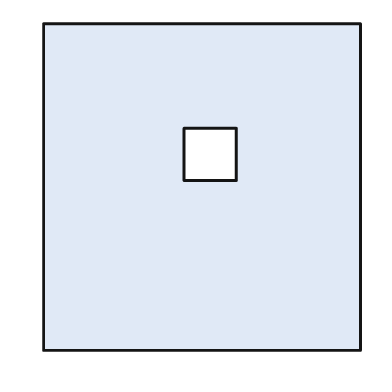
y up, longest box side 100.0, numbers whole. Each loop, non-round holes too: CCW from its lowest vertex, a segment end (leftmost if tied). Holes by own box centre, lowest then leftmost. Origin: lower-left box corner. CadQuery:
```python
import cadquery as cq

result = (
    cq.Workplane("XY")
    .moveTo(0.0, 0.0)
    .lineTo(97.0, 0.0)
    .lineTo(97.0, 100.0)
    .lineTo(0.0, 100.0)
    .close()
    .moveTo(43.0, 52.0)
    .lineTo(59.0, 52.0)
    .lineTo(59.0, 68.0)
    .lineTo(43.0, 68.0)
    .close()
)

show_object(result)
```